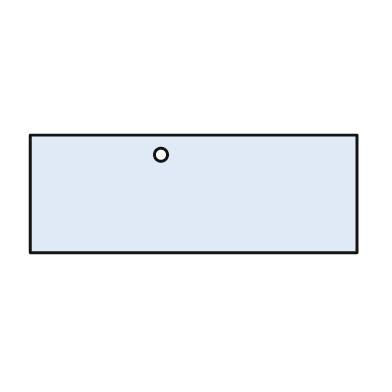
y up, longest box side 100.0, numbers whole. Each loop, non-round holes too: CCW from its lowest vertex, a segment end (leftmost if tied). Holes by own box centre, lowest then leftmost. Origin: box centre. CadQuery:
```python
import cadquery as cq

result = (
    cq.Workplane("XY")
    .moveTo(-50.0, -18.0)
    .lineTo(50.0, -18.0)
    .lineTo(50.0, 18.0)
    .lineTo(-50.0, 18.0)
    .close()
    .moveTo(-10.0, 12.0)
    .circle(2.0)
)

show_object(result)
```